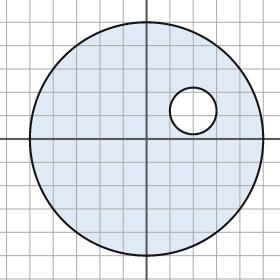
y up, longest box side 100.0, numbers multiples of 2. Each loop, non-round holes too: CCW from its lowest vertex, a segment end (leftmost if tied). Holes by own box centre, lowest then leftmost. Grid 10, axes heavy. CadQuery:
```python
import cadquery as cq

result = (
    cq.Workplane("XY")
    .moveTo(0.0, 0.0)
    .circle(50.0)
    .moveTo(20.0, 12.0)
    .circle(10.0)
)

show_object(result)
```